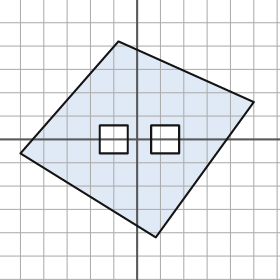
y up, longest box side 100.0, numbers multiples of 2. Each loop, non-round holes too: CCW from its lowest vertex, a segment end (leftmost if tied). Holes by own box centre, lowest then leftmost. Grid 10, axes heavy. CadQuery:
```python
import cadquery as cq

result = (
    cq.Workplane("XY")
    .moveTo(8.0, -42.0)
    .lineTo(50.0, 16.0)
    .lineTo(-8.0, 42.0)
    .lineTo(-50.0, -6.0)
    .close()
    .moveTo(-16.0, -6.0)
    .lineTo(-4.0, -6.0)
    .lineTo(-4.0, 6.0)
    .lineTo(-16.0, 6.0)
    .close()
    .moveTo(6.0, -6.0)
    .lineTo(18.0, -6.0)
    .lineTo(18.0, 6.0)
    .lineTo(6.0, 6.0)
    .close()
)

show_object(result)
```